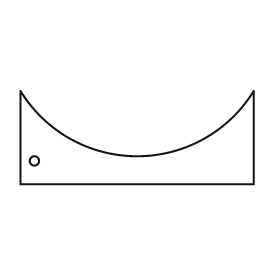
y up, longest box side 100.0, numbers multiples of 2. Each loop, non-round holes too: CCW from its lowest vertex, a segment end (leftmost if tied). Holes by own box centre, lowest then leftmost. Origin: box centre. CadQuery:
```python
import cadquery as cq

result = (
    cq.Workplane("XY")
    .moveTo(-50.0, -20.0)
    .lineTo(50.0, -20.0)
    .lineTo(50.0, 20.0)
    .threePointArc((0.0, -8.0), (-50.0, 20.0))
    .close()
    .moveTo(-44.0, -10.0)
    .circle(2.0)
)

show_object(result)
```